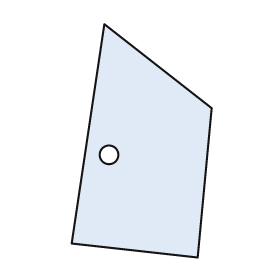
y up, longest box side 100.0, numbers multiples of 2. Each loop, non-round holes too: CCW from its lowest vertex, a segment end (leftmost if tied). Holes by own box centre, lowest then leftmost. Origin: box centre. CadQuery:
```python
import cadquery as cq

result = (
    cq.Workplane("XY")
    .moveTo(24.0, -50.0)
    .lineTo(30.0, 14.0)
    .lineTo(-16.0, 50.0)
    .lineTo(-30.0, -44.0)
    .close()
    .moveTo(-14.0, -6.0)
    .circle(4.0)
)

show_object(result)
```